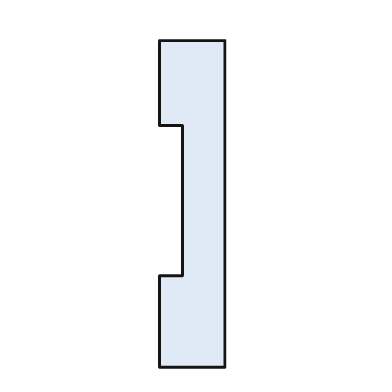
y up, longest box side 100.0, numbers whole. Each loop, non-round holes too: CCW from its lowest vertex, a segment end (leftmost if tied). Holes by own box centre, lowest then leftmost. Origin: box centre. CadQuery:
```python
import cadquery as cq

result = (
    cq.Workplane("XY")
    .moveTo(-10.0, -50.0)
    .lineTo(10.0, -50.0)
    .lineTo(10.0, 50.0)
    .lineTo(-10.0, 50.0)
    .lineTo(-10.0, 24.0)
    .lineTo(-3.0, 24.0)
    .lineTo(-3.0, -22.0)
    .lineTo(-10.0, -22.0)
    .close()
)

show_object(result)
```